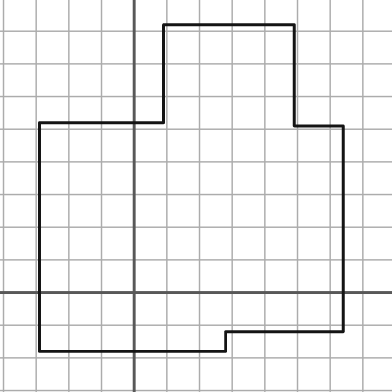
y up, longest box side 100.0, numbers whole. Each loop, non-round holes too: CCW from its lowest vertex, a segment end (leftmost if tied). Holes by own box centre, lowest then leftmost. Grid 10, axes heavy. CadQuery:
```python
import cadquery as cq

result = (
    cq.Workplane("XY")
    .moveTo(-29.0, -18.0)
    .lineTo(28.0, -18.0)
    .lineTo(28.0, -12.0)
    .lineTo(64.0, -12.0)
    .lineTo(64.0, 51.0)
    .lineTo(49.0, 51.0)
    .lineTo(49.0, 82.0)
    .lineTo(9.0, 82.0)
    .lineTo(9.0, 52.0)
    .lineTo(-29.0, 52.0)
    .close()
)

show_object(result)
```